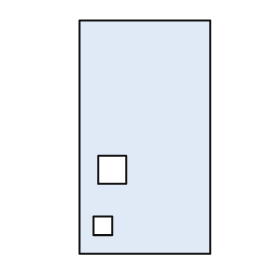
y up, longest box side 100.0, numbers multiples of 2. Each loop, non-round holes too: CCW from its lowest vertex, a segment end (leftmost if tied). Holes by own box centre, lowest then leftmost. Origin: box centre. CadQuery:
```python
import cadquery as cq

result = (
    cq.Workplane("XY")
    .moveTo(-28.0, -50.0)
    .lineTo(28.0, -50.0)
    .lineTo(28.0, 50.0)
    .lineTo(-28.0, 50.0)
    .close()
    .moveTo(-22.0, -42.0)
    .lineTo(-14.0, -42.0)
    .lineTo(-14.0, -34.0)
    .lineTo(-22.0, -34.0)
    .close()
    .moveTo(-20.0, -20.0)
    .lineTo(-8.0, -20.0)
    .lineTo(-8.0, -8.0)
    .lineTo(-20.0, -8.0)
    .close()
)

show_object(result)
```